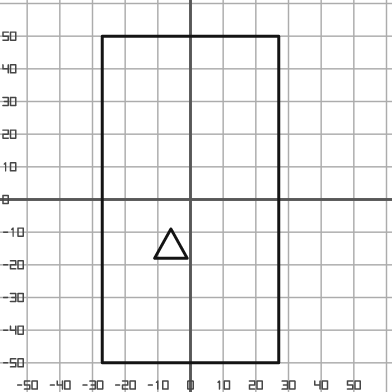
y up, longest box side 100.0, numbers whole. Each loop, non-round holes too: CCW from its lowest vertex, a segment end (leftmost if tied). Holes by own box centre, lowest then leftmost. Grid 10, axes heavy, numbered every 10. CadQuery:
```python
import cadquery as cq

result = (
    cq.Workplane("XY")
    .moveTo(-27.0, -50.0)
    .lineTo(27.0, -50.0)
    .lineTo(27.0, 50.0)
    .lineTo(-27.0, 50.0)
    .close()
    .moveTo(-11.0, -18.0)
    .lineTo(-1.0, -18.0)
    .lineTo(-6.0, -9.0)
    .close()
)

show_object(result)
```